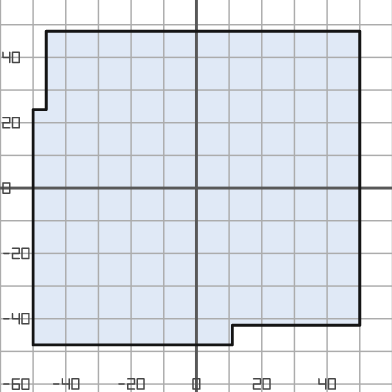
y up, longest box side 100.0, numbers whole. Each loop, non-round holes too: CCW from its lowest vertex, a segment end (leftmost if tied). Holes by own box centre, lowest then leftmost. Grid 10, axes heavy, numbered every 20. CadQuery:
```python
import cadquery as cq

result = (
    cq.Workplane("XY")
    .moveTo(-50.0, -48.0)
    .lineTo(11.0, -48.0)
    .lineTo(11.0, -42.0)
    .lineTo(50.0, -42.0)
    .lineTo(50.0, 48.0)
    .lineTo(-46.0, 48.0)
    .lineTo(-46.0, 24.0)
    .lineTo(-50.0, 24.0)
    .close()
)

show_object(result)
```